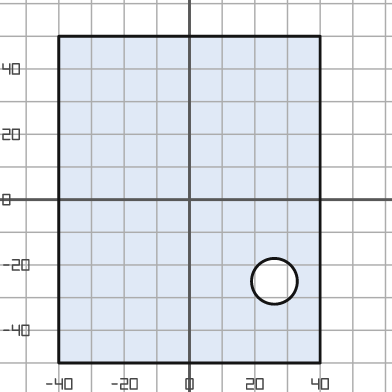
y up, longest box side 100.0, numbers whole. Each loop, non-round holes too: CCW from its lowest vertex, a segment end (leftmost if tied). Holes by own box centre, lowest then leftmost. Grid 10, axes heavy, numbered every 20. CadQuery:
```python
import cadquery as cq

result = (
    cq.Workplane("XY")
    .moveTo(-40.0, -50.0)
    .lineTo(40.0, -50.0)
    .lineTo(40.0, 50.0)
    .lineTo(-40.0, 50.0)
    .close()
    .moveTo(26.0, -25.0)
    .circle(7.0)
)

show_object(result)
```